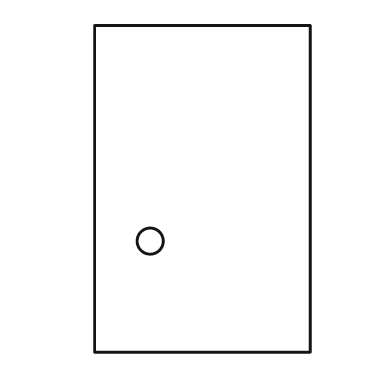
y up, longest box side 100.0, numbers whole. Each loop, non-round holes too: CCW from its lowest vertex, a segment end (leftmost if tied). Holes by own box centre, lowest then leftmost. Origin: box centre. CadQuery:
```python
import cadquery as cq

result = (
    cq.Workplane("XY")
    .moveTo(-33.0, -50.0)
    .lineTo(33.0, -50.0)
    .lineTo(33.0, 50.0)
    .lineTo(-33.0, 50.0)
    .close()
    .moveTo(-16.0, -16.0)
    .circle(4.0)
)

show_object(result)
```